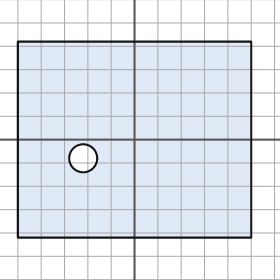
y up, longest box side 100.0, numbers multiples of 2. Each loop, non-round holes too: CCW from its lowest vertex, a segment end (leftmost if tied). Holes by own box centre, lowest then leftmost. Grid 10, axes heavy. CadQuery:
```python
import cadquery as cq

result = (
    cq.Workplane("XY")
    .moveTo(-50.0, -42.0)
    .lineTo(50.0, -42.0)
    .lineTo(50.0, 42.0)
    .lineTo(-50.0, 42.0)
    .close()
    .moveTo(-22.0, -8.0)
    .circle(6.0)
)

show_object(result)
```